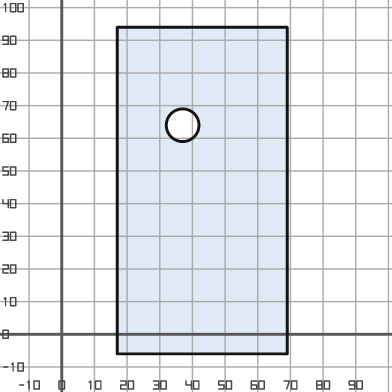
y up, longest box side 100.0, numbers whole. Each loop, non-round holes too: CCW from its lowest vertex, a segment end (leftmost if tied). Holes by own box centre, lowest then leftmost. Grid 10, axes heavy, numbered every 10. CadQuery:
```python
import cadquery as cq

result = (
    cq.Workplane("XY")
    .moveTo(17.0, -6.0)
    .lineTo(69.0, -6.0)
    .lineTo(69.0, 94.0)
    .lineTo(17.0, 94.0)
    .close()
    .moveTo(37.0, 64.0)
    .circle(5.0)
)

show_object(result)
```